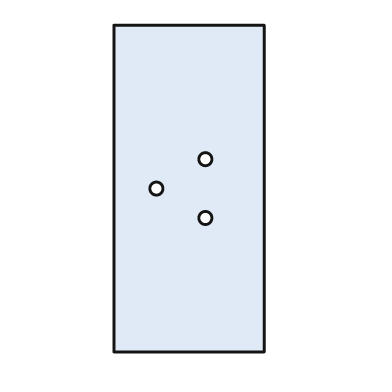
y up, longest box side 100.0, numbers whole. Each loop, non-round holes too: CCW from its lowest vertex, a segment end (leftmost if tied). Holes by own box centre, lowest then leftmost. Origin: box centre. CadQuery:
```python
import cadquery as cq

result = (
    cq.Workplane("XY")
    .moveTo(-23.0, -50.0)
    .lineTo(23.0, -50.0)
    .lineTo(23.0, 50.0)
    .lineTo(-23.0, 50.0)
    .close()
    .moveTo(5.0, -9.0)
    .circle(2.0)
    .moveTo(-10.0, 0.0)
    .circle(2.0)
    .moveTo(5.0, 9.0)
    .circle(2.0)
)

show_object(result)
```